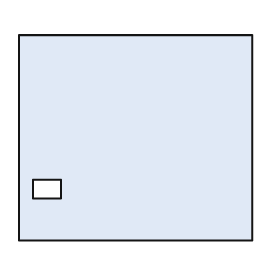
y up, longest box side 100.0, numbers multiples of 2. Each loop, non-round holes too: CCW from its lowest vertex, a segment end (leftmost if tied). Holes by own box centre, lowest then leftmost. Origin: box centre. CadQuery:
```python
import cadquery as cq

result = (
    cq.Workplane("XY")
    .moveTo(-50.0, -44.0)
    .lineTo(50.0, -44.0)
    .lineTo(50.0, 44.0)
    .lineTo(-50.0, 44.0)
    .close()
    .moveTo(-44.0, -26.0)
    .lineTo(-32.0, -26.0)
    .lineTo(-32.0, -18.0)
    .lineTo(-44.0, -18.0)
    .close()
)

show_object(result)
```